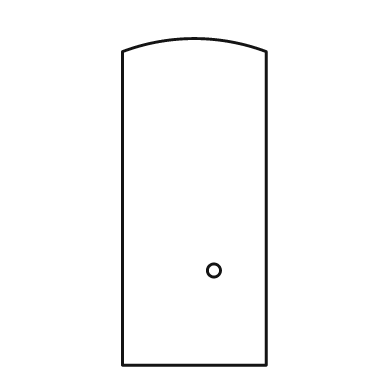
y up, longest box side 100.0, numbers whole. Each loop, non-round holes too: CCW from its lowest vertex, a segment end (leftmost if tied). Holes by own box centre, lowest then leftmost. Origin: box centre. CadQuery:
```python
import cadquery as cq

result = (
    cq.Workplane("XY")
    .moveTo(-22.0, -50.0)
    .lineTo(22.0, -50.0)
    .lineTo(22.0, 46.0)
    .threePointArc((0.0, 50.0), (-22.0, 46.0))
    .close()
    .moveTo(6.0, -21.0)
    .circle(2.0)
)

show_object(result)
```